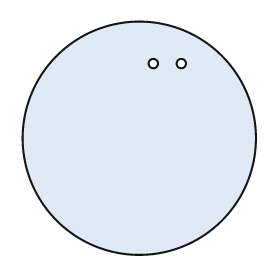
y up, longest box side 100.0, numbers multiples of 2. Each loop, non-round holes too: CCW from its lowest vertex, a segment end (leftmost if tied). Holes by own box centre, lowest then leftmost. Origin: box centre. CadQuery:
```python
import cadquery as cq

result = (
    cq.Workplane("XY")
    .moveTo(0.0, 0.0)
    .circle(50.0)
    .moveTo(6.0, 32.0)
    .circle(2.0)
    .moveTo(18.0, 32.0)
    .circle(2.0)
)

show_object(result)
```